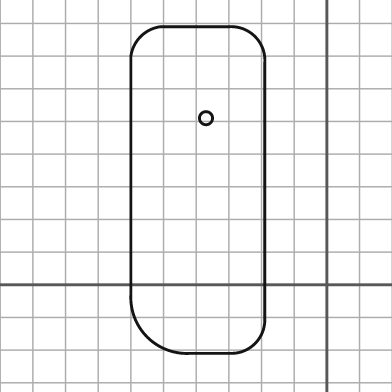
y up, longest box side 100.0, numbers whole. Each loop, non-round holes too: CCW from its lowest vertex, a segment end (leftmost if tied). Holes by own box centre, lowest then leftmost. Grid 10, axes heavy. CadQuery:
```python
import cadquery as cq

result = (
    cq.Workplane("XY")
    .moveTo(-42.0, -21.0)
    .lineTo(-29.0, -21.0)
    .threePointArc((-22.0, -18.0), (-19.0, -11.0))
    .lineTo(-19.0, 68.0)
    .threePointArc((-22.0, 76.0), (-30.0, 79.0))
    .lineTo(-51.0, 79.0)
    .threePointArc((-57.0, 76.0), (-60.0, 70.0))
    .lineTo(-60.0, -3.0)
    .threePointArc((-55.0, -16.0), (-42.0, -21.0))
    .close()
    .moveTo(-37.0, 51.0)
    .circle(2.0)
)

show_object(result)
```